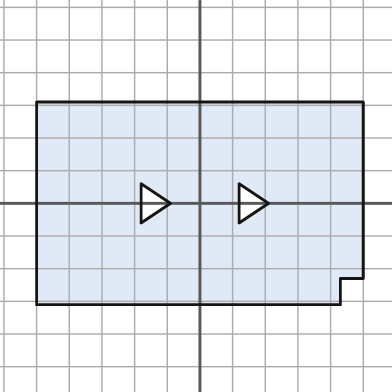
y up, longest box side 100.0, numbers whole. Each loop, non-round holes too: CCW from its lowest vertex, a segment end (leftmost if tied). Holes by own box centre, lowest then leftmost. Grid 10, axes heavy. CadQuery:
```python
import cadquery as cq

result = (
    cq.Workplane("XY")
    .moveTo(-50.0, -31.0)
    .lineTo(43.0, -31.0)
    .lineTo(43.0, -23.0)
    .lineTo(50.0, -23.0)
    .lineTo(50.0, 31.0)
    .lineTo(-50.0, 31.0)
    .close()
    .moveTo(-18.0, -6.0)
    .lineTo(-9.0, 0.0)
    .lineTo(-18.0, 6.0)
    .close()
    .moveTo(12.0, -6.0)
    .lineTo(21.0, 0.0)
    .lineTo(12.0, 6.0)
    .close()
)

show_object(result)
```